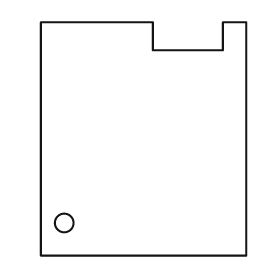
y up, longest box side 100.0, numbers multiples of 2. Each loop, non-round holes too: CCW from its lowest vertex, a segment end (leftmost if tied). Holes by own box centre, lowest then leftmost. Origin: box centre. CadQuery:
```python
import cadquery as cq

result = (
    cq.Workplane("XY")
    .moveTo(-44.0, -50.0)
    .lineTo(44.0, -50.0)
    .lineTo(44.0, 50.0)
    .lineTo(34.0, 50.0)
    .lineTo(34.0, 38.0)
    .lineTo(4.0, 38.0)
    .lineTo(4.0, 50.0)
    .lineTo(-44.0, 50.0)
    .close()
    .moveTo(-34.0, -36.0)
    .circle(4.0)
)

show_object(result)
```